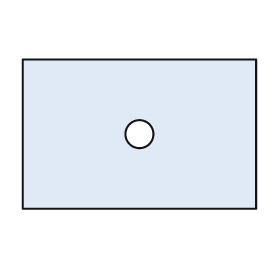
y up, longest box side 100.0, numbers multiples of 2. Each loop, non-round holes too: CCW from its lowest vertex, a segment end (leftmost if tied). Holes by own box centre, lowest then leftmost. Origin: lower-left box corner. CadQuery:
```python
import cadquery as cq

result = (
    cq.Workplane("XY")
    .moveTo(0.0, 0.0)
    .lineTo(100.0, 0.0)
    .lineTo(100.0, 64.0)
    .lineTo(0.0, 64.0)
    .close()
    .moveTo(50.0, 32.0)
    .circle(6.0)
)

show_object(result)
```